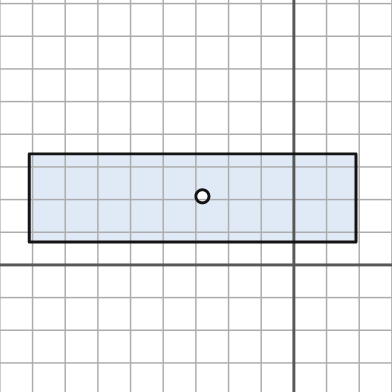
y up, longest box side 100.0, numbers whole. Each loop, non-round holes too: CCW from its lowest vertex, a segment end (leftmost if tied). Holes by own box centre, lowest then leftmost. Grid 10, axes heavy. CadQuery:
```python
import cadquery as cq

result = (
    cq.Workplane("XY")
    .moveTo(-81.0, 7.0)
    .lineTo(19.0, 7.0)
    .lineTo(19.0, 34.0)
    .lineTo(-81.0, 34.0)
    .close()
    .moveTo(-28.0, 21.0)
    .circle(2.0)
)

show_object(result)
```